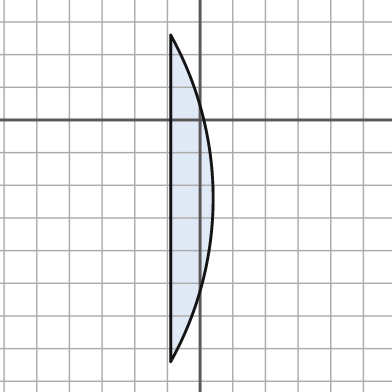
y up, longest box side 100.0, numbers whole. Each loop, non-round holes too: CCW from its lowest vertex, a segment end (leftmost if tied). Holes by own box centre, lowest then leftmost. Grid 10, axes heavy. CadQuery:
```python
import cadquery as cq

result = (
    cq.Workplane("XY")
    .moveTo(-9.0, -74.0)
    .threePointArc((4.0, -24.0), (-9.0, 26.0))
    .close()
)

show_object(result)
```